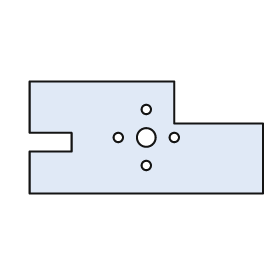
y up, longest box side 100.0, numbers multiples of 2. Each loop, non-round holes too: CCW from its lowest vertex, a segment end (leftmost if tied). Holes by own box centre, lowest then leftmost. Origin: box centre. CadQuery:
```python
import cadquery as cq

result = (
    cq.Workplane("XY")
    .moveTo(-50.0, -24.0)
    .lineTo(50.0, -24.0)
    .lineTo(50.0, 6.0)
    .lineTo(12.0, 6.0)
    .lineTo(12.0, 24.0)
    .lineTo(-50.0, 24.0)
    .lineTo(-50.0, 2.0)
    .lineTo(-32.0, 2.0)
    .lineTo(-32.0, -6.0)
    .lineTo(-50.0, -6.0)
    .close()
    .moveTo(0.0, -12.0)
    .circle(2.0)
    .moveTo(-12.0, 0.0)
    .circle(2.0)
    .moveTo(0.0, 0.0)
    .circle(4.0)
    .moveTo(12.0, 0.0)
    .circle(2.0)
    .moveTo(0.0, 12.0)
    .circle(2.0)
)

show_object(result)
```